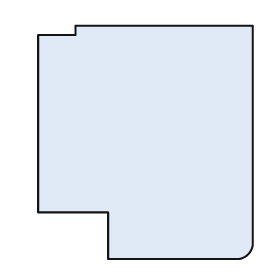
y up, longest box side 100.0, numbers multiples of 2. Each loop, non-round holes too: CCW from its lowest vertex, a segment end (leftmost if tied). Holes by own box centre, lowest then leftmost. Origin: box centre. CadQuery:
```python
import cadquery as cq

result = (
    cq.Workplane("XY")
    .moveTo(-16.0, -50.0)
    .lineTo(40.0, -50.0)
    .threePointArc((44.0, -48.0), (46.0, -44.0))
    .lineTo(46.0, 50.0)
    .lineTo(-30.0, 50.0)
    .lineTo(-30.0, 46.0)
    .lineTo(-46.0, 46.0)
    .lineTo(-46.0, -30.0)
    .lineTo(-16.0, -30.0)
    .close()
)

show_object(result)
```